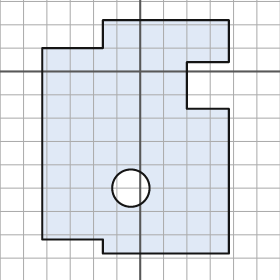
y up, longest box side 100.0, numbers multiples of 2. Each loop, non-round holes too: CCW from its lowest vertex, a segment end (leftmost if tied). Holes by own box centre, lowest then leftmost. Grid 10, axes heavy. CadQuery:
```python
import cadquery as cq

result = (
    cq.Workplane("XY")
    .moveTo(-16.0, -78.0)
    .lineTo(38.0, -78.0)
    .lineTo(38.0, -16.0)
    .lineTo(20.0, -16.0)
    .lineTo(20.0, 4.0)
    .lineTo(38.0, 4.0)
    .lineTo(38.0, 22.0)
    .lineTo(-16.0, 22.0)
    .lineTo(-16.0, 10.0)
    .lineTo(-42.0, 10.0)
    .lineTo(-42.0, -72.0)
    .lineTo(-16.0, -72.0)
    .close()
    .moveTo(-4.0, -50.0)
    .circle(8.0)
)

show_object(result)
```